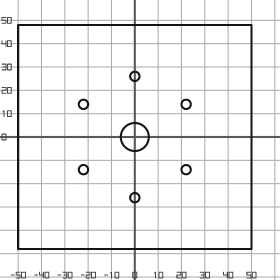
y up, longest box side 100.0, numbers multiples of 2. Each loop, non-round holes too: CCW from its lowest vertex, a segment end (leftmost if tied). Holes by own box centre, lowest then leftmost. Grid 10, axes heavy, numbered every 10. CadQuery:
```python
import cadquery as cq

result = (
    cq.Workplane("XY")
    .moveTo(-50.0, -48.0)
    .lineTo(50.0, -48.0)
    .lineTo(50.0, 48.0)
    .lineTo(-50.0, 48.0)
    .close()
    .moveTo(0.0, -26.0)
    .circle(2.0)
    .moveTo(-22.0, -14.0)
    .circle(2.0)
    .moveTo(22.0, -14.0)
    .circle(2.0)
    .moveTo(0.0, 0.0)
    .circle(6.0)
    .moveTo(-22.0, 14.0)
    .circle(2.0)
    .moveTo(22.0, 14.0)
    .circle(2.0)
    .moveTo(0.0, 26.0)
    .circle(2.0)
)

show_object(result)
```